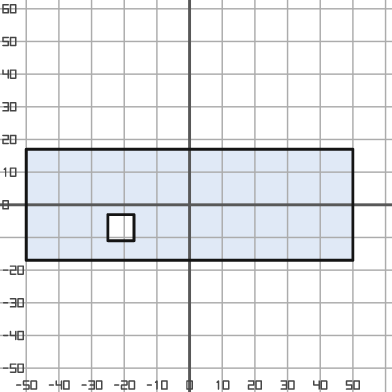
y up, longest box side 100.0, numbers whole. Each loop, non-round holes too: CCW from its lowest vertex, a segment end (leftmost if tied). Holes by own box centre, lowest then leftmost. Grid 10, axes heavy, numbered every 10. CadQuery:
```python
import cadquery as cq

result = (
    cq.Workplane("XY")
    .moveTo(-50.0, -17.0)
    .lineTo(50.0, -17.0)
    .lineTo(50.0, 17.0)
    .lineTo(-50.0, 17.0)
    .close()
    .moveTo(-25.0, -11.0)
    .lineTo(-17.0, -11.0)
    .lineTo(-17.0, -3.0)
    .lineTo(-25.0, -3.0)
    .close()
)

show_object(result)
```